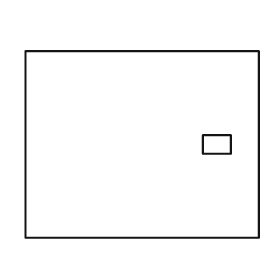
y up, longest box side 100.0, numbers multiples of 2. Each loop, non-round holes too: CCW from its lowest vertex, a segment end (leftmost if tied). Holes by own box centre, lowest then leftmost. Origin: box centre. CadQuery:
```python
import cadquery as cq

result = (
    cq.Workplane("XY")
    .moveTo(-50.0, -40.0)
    .lineTo(50.0, -40.0)
    .lineTo(50.0, 40.0)
    .lineTo(-50.0, 40.0)
    .close()
    .moveTo(26.0, -4.0)
    .lineTo(38.0, -4.0)
    .lineTo(38.0, 4.0)
    .lineTo(26.0, 4.0)
    .close()
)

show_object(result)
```